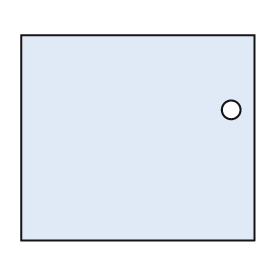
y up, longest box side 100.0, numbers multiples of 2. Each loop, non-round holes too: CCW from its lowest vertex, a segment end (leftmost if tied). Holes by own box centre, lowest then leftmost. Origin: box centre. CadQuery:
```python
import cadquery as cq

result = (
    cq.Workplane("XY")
    .moveTo(-50.0, -44.0)
    .lineTo(50.0, -44.0)
    .lineTo(50.0, 44.0)
    .lineTo(-50.0, 44.0)
    .close()
    .moveTo(40.0, 12.0)
    .circle(4.0)
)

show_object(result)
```